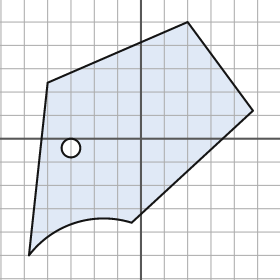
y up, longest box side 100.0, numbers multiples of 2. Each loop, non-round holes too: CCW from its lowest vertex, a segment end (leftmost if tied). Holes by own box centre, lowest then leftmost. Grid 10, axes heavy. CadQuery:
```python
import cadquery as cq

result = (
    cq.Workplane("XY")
    .moveTo(-48.0, -50.0)
    .threePointArc((-28.0, -36.0), (-4.0, -36.0))
    .lineTo(48.0, 12.0)
    .lineTo(20.0, 50.0)
    .lineTo(-40.0, 24.0)
    .close()
    .moveTo(-30.0, -4.0)
    .circle(4.0)
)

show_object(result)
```